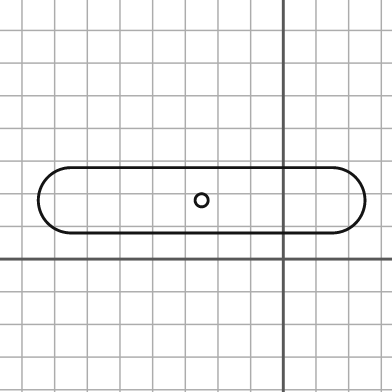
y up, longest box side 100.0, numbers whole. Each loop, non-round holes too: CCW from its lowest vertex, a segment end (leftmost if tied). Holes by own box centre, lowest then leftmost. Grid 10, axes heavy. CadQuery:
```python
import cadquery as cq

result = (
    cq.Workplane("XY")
    .moveTo(-65.0, 8.0)
    .lineTo(15.0, 8.0)
    .threePointArc((25.0, 18.0), (15.0, 28.0))
    .lineTo(-65.0, 28.0)
    .threePointArc((-75.0, 18.0), (-65.0, 8.0))
    .close()
    .moveTo(-25.0, 18.0)
    .circle(2.0)
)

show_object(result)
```